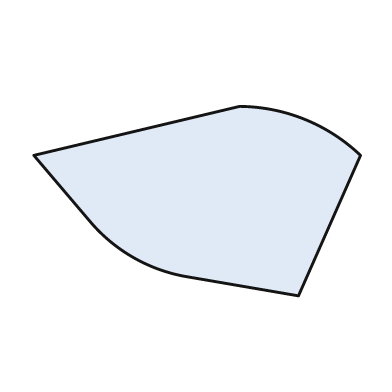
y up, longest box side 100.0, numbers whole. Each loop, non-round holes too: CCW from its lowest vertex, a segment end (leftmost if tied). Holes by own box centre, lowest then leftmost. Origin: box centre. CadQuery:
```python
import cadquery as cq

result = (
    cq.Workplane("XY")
    .moveTo(31.0, -29.0)
    .lineTo(50.0, 14.0)
    .threePointArc((33.0, 25.0), (13.0, 29.0))
    .lineTo(-50.0, 14.0)
    .lineTo(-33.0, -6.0)
    .threePointArc((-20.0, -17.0), (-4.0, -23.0))
    .close()
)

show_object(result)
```